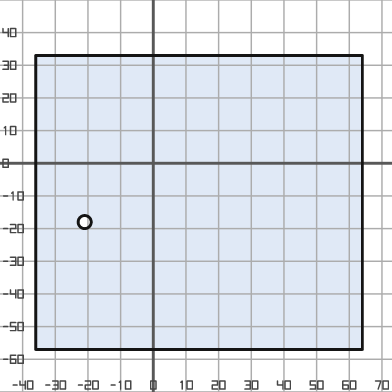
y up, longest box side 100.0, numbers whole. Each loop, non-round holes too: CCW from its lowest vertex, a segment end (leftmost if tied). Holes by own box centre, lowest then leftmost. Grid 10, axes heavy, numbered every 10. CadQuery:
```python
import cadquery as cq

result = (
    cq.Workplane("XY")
    .moveTo(-36.0, -57.0)
    .lineTo(64.0, -57.0)
    .lineTo(64.0, 33.0)
    .lineTo(-36.0, 33.0)
    .close()
    .moveTo(-21.0, -18.0)
    .circle(2.0)
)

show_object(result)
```